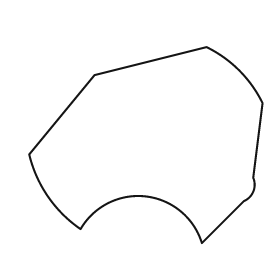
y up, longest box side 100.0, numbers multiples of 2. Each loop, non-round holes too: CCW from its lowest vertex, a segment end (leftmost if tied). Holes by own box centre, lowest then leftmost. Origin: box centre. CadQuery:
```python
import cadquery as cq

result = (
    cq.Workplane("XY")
    .moveTo(24.0, -42.0)
    .lineTo(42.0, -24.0)
    .threePointArc((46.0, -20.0), (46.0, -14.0))
    .lineTo(50.0, 18.0)
    .threePointArc((40.0, 32.0), (26.0, 42.0))
    .lineTo(-22.0, 30.0)
    .lineTo(-50.0, -4.0)
    .threePointArc((-42.0, -22.0), (-28.0, -36.0))
    .threePointArc((0.0, -22.0), (24.0, -42.0))
    .close()
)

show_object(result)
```